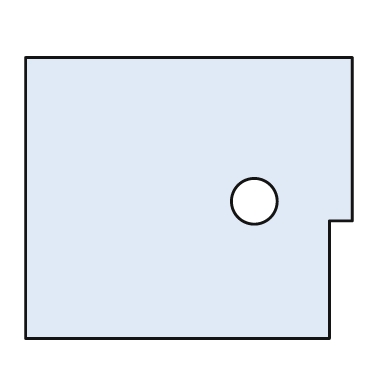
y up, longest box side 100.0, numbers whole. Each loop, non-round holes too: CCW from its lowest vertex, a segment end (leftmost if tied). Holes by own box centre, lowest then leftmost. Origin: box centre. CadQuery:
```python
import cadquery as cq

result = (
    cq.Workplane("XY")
    .moveTo(-50.0, -43.0)
    .lineTo(43.0, -43.0)
    .lineTo(43.0, -7.0)
    .lineTo(50.0, -7.0)
    .lineTo(50.0, 43.0)
    .lineTo(-50.0, 43.0)
    .close()
    .moveTo(20.0, -1.0)
    .circle(7.0)
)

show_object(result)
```